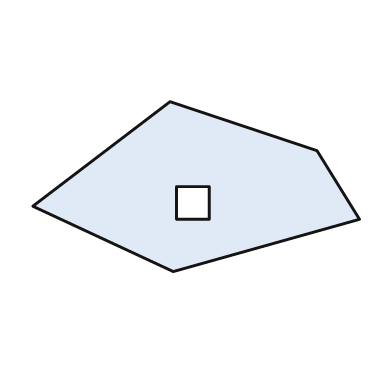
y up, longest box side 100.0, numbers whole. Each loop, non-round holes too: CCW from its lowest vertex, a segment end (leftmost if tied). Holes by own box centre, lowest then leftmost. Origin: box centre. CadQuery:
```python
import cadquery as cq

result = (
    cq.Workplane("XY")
    .moveTo(-7.0, -26.0)
    .lineTo(50.0, -10.0)
    .lineTo(37.0, 11.0)
    .lineTo(-8.0, 26.0)
    .lineTo(-50.0, -6.0)
    .close()
    .moveTo(-6.0, -10.0)
    .lineTo(4.0, -10.0)
    .lineTo(4.0, 0.0)
    .lineTo(-6.0, 0.0)
    .close()
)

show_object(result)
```